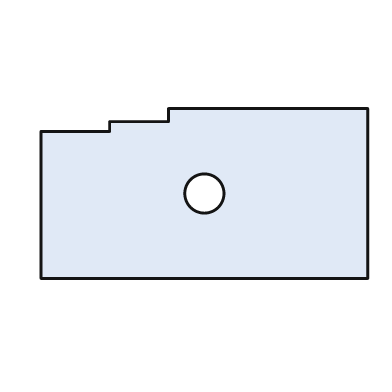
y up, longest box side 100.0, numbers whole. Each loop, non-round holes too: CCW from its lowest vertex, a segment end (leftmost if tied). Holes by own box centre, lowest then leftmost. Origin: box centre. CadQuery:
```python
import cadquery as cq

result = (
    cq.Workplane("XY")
    .moveTo(-50.0, -26.0)
    .lineTo(50.0, -26.0)
    .lineTo(50.0, 26.0)
    .lineTo(-11.0, 26.0)
    .lineTo(-11.0, 22.0)
    .lineTo(-29.0, 22.0)
    .lineTo(-29.0, 19.0)
    .lineTo(-50.0, 19.0)
    .close()
    .moveTo(0.0, 0.0)
    .circle(6.0)
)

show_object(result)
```